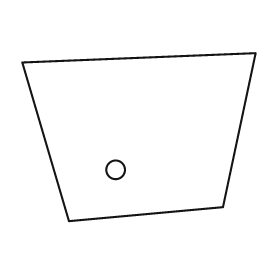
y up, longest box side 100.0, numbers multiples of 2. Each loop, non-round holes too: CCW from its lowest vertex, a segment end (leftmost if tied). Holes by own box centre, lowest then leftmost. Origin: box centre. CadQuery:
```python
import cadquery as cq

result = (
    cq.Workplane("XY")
    .moveTo(-30.0, -36.0)
    .lineTo(36.0, -30.0)
    .lineTo(50.0, 36.0)
    .lineTo(-50.0, 32.0)
    .close()
    .moveTo(-10.0, -14.0)
    .circle(4.0)
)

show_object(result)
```